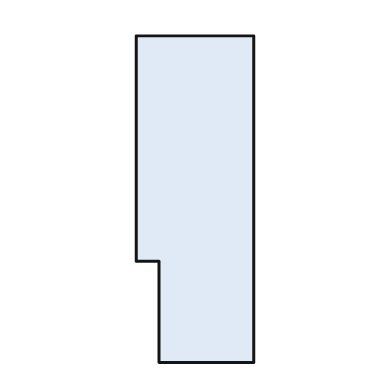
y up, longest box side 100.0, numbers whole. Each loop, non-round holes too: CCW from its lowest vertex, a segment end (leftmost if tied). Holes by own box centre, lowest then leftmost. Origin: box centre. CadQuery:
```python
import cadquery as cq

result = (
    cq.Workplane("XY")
    .moveTo(-11.0, -50.0)
    .lineTo(18.0, -50.0)
    .lineTo(18.0, 50.0)
    .lineTo(-18.0, 50.0)
    .lineTo(-18.0, -19.0)
    .lineTo(-11.0, -19.0)
    .close()
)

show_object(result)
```